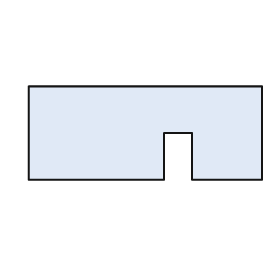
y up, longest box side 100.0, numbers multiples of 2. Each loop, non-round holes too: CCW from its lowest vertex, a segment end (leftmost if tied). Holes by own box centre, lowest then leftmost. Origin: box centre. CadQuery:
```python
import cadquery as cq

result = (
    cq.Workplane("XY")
    .moveTo(-50.0, -20.0)
    .lineTo(8.0, -20.0)
    .lineTo(8.0, 0.0)
    .lineTo(20.0, 0.0)
    .lineTo(20.0, -20.0)
    .lineTo(50.0, -20.0)
    .lineTo(50.0, 20.0)
    .lineTo(-50.0, 20.0)
    .close()
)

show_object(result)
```